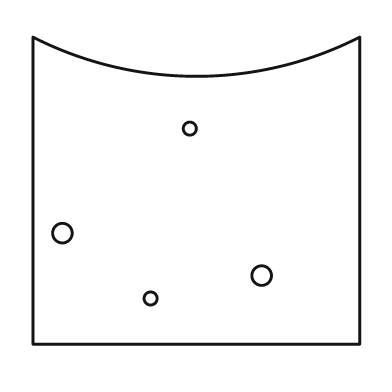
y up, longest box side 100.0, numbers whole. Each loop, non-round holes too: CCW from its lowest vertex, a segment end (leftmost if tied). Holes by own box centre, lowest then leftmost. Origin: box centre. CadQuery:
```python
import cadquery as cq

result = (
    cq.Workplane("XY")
    .moveTo(-50.0, -47.0)
    .lineTo(50.0, -47.0)
    .lineTo(50.0, 47.0)
    .threePointArc((0.0, 35.0), (-50.0, 47.0))
    .close()
    .moveTo(-14.0, -33.0)
    .circle(2.0)
    .moveTo(20.0, -26.0)
    .circle(3.0)
    .moveTo(-41.0, -13.0)
    .circle(3.0)
    .moveTo(-2.0, 19.0)
    .circle(2.0)
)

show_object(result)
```